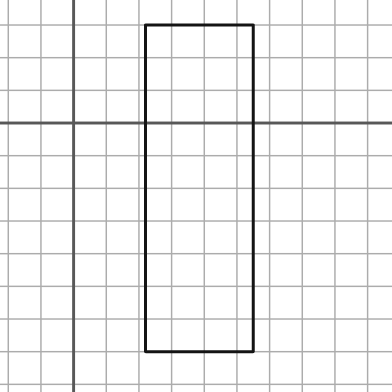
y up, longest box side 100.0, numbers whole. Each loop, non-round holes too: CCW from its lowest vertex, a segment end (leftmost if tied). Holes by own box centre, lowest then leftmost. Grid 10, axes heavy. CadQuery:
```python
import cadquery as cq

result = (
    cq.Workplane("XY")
    .moveTo(22.0, -70.0)
    .lineTo(55.0, -70.0)
    .lineTo(55.0, 30.0)
    .lineTo(22.0, 30.0)
    .close()
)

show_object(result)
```